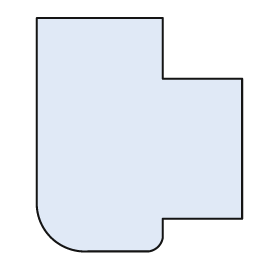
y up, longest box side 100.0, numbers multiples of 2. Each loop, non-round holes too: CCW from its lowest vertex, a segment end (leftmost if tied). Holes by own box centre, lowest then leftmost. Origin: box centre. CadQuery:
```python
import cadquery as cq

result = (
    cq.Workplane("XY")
    .moveTo(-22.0, -50.0)
    .lineTo(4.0, -50.0)
    .threePointArc((8.0, -48.0), (10.0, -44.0))
    .lineTo(10.0, -36.0)
    .lineTo(44.0, -36.0)
    .lineTo(44.0, 24.0)
    .lineTo(10.0, 24.0)
    .lineTo(10.0, 50.0)
    .lineTo(-44.0, 50.0)
    .lineTo(-44.0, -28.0)
    .threePointArc((-38.0, -44.0), (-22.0, -50.0))
    .close()
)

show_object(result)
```